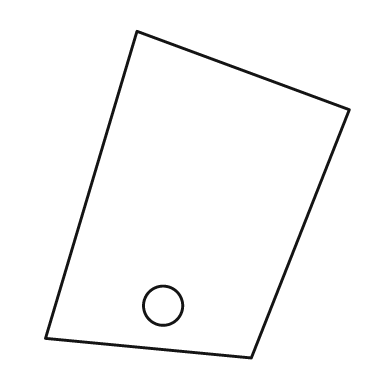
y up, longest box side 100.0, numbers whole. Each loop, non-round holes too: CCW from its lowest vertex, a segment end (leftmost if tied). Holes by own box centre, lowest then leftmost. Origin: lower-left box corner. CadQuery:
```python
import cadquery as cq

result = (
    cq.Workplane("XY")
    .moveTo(63.0, 0.0)
    .lineTo(93.0, 76.0)
    .lineTo(28.0, 100.0)
    .lineTo(0.0, 6.0)
    .close()
    .moveTo(36.0, 16.0)
    .circle(6.0)
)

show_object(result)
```